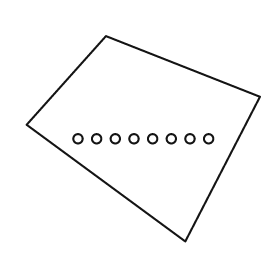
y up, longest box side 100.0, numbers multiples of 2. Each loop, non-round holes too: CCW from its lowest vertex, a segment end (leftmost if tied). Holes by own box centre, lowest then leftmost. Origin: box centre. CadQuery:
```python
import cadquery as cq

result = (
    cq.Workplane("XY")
    .moveTo(18.0, -44.0)
    .lineTo(50.0, 18.0)
    .lineTo(-16.0, 44.0)
    .lineTo(-50.0, 6.0)
    .close()
    .moveTo(-28.0, 0.0)
    .circle(2.0)
    .moveTo(-20.0, 0.0)
    .circle(2.0)
    .moveTo(-12.0, 0.0)
    .circle(2.0)
    .moveTo(-4.0, 0.0)
    .circle(2.0)
    .moveTo(4.0, 0.0)
    .circle(2.0)
    .moveTo(12.0, 0.0)
    .circle(2.0)
    .moveTo(20.0, 0.0)
    .circle(2.0)
    .moveTo(28.0, 0.0)
    .circle(2.0)
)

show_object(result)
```